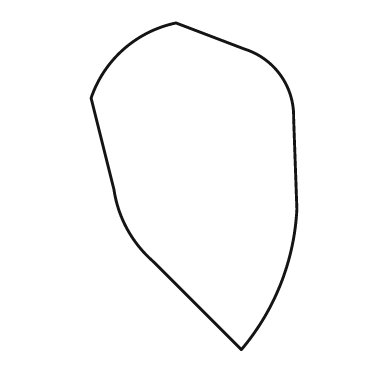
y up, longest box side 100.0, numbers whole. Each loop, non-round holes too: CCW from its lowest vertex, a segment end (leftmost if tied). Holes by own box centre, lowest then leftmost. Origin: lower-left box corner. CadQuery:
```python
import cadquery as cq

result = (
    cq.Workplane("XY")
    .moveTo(46.0, 0.0)
    .threePointArc((58.0, 20.0), (63.0, 43.0))
    .lineTo(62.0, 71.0)
    .threePointArc((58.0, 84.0), (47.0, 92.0))
    .lineTo(26.0, 100.0)
    .threePointArc((10.0, 92.0), (0.0, 77.0))
    .lineTo(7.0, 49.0)
    .threePointArc((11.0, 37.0), (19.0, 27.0))
    .close()
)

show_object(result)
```